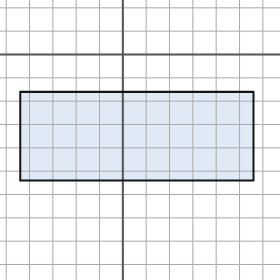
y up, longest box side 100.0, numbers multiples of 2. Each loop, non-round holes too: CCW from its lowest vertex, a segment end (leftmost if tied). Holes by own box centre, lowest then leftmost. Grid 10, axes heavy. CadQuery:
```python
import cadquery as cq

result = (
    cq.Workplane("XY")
    .moveTo(-44.0, -54.0)
    .lineTo(56.0, -54.0)
    .lineTo(56.0, -16.0)
    .lineTo(-44.0, -16.0)
    .close()
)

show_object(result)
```